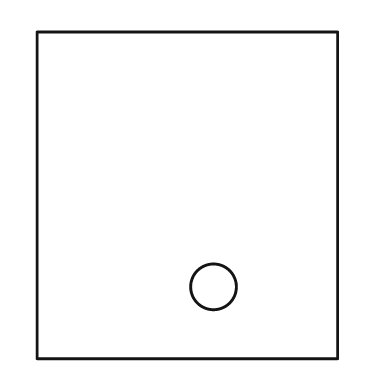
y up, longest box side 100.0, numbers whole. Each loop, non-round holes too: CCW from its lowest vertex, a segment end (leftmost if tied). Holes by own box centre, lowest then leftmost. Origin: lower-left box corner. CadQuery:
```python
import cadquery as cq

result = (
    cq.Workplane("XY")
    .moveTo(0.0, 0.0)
    .lineTo(92.0, 0.0)
    .lineTo(92.0, 100.0)
    .lineTo(0.0, 100.0)
    .close()
    .moveTo(54.0, 22.0)
    .circle(7.0)
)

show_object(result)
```